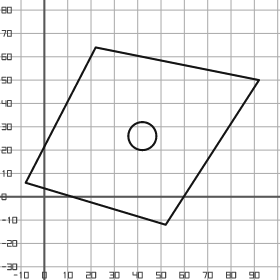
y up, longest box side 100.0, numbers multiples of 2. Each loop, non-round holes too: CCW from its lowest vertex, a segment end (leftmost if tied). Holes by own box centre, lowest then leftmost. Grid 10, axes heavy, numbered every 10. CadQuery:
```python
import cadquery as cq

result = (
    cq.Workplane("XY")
    .moveTo(52.0, -12.0)
    .lineTo(92.0, 50.0)
    .lineTo(22.0, 64.0)
    .lineTo(-8.0, 6.0)
    .close()
    .moveTo(42.0, 26.0)
    .circle(6.0)
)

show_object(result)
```